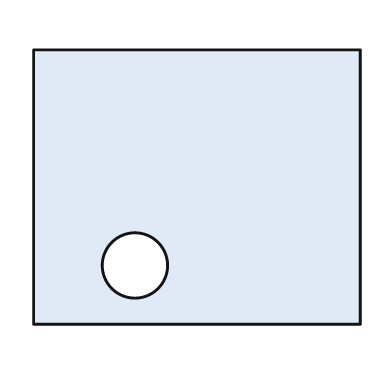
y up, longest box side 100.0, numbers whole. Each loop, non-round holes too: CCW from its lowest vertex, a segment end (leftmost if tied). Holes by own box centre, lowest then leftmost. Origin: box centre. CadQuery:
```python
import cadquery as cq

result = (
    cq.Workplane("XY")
    .moveTo(-50.0, -42.0)
    .lineTo(50.0, -42.0)
    .lineTo(50.0, 42.0)
    .lineTo(-50.0, 42.0)
    .close()
    .moveTo(-19.0, -24.0)
    .circle(10.0)
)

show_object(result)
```